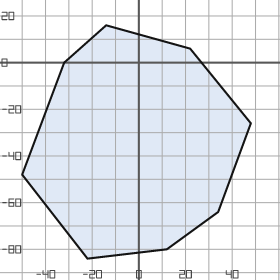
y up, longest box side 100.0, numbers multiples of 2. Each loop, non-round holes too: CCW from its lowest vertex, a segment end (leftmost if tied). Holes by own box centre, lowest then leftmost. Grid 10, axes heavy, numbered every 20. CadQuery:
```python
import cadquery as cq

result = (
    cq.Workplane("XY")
    .moveTo(-22.0, -84.0)
    .lineTo(12.0, -80.0)
    .lineTo(34.0, -64.0)
    .lineTo(48.0, -26.0)
    .lineTo(22.0, 6.0)
    .lineTo(-14.0, 16.0)
    .lineTo(-32.0, 0.0)
    .lineTo(-50.0, -48.0)
    .close()
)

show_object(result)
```